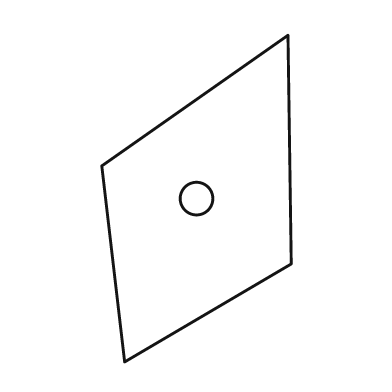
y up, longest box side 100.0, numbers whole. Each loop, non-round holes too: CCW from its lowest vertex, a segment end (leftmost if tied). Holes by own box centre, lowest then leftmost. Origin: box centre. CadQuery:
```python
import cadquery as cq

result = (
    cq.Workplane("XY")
    .moveTo(-22.0, -50.0)
    .lineTo(29.0, -20.0)
    .lineTo(28.0, 50.0)
    .lineTo(-29.0, 10.0)
    .close()
    .moveTo(0.0, 0.0)
    .circle(5.0)
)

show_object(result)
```